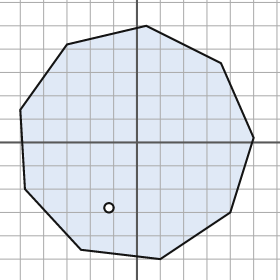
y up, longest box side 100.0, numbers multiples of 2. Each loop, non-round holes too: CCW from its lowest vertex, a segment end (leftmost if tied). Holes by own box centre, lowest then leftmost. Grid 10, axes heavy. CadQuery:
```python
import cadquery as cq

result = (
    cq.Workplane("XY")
    .moveTo(10.0, -50.0)
    .lineTo(40.0, -30.0)
    .lineTo(50.0, 2.0)
    .lineTo(36.0, 34.0)
    .lineTo(4.0, 50.0)
    .lineTo(-30.0, 42.0)
    .lineTo(-50.0, 14.0)
    .lineTo(-48.0, -20.0)
    .lineTo(-24.0, -46.0)
    .close()
    .moveTo(-12.0, -28.0)
    .circle(2.0)
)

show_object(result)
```